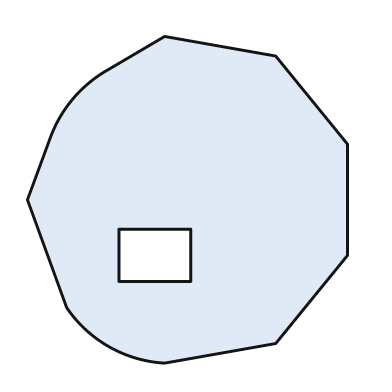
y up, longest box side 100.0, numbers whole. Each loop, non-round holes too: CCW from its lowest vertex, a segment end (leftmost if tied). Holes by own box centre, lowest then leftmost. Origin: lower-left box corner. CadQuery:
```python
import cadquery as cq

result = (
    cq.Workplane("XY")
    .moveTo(42.0, 0.0)
    .lineTo(76.0, 6.0)
    .lineTo(98.0, 33.0)
    .lineTo(98.0, 67.0)
    .lineTo(76.0, 94.0)
    .lineTo(42.0, 100.0)
    .lineTo(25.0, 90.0)
    .threePointArc((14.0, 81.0), (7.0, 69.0))
    .lineTo(0.0, 50.0)
    .lineTo(12.0, 17.0)
    .threePointArc((25.0, 5.0), (42.0, 0.0))
    .close()
    .moveTo(28.0, 25.0)
    .lineTo(50.0, 25.0)
    .lineTo(50.0, 41.0)
    .lineTo(28.0, 41.0)
    .close()
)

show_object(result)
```